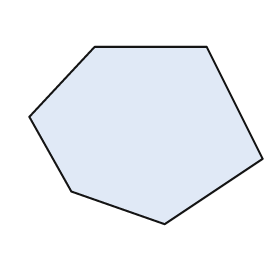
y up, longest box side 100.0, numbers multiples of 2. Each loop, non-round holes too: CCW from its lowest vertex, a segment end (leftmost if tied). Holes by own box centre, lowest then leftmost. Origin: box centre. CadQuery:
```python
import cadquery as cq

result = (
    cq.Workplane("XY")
    .moveTo(8.0, -38.0)
    .lineTo(50.0, -10.0)
    .lineTo(26.0, 38.0)
    .lineTo(-22.0, 38.0)
    .lineTo(-50.0, 8.0)
    .lineTo(-32.0, -24.0)
    .close()
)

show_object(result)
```